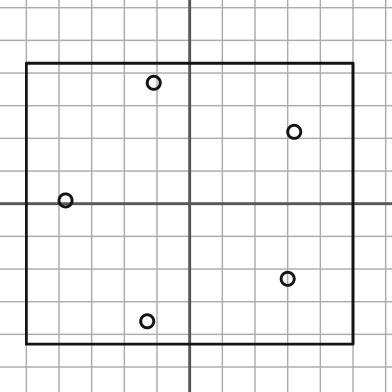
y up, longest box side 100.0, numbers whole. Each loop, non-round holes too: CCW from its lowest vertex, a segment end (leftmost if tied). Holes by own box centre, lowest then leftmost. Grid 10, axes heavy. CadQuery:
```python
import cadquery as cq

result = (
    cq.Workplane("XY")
    .moveTo(-50.0, -43.0)
    .lineTo(50.0, -43.0)
    .lineTo(50.0, 43.0)
    .lineTo(-50.0, 43.0)
    .close()
    .moveTo(-13.0, -36.0)
    .circle(2.0)
    .moveTo(30.0, -23.0)
    .circle(2.0)
    .moveTo(-38.0, 1.0)
    .circle(2.0)
    .moveTo(32.0, 22.0)
    .circle(2.0)
    .moveTo(-11.0, 37.0)
    .circle(2.0)
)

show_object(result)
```